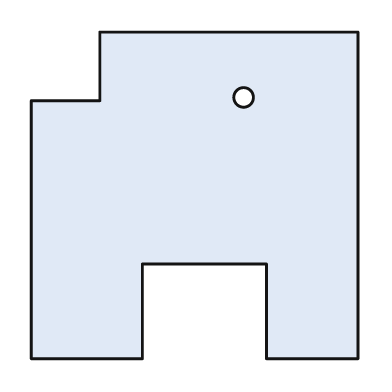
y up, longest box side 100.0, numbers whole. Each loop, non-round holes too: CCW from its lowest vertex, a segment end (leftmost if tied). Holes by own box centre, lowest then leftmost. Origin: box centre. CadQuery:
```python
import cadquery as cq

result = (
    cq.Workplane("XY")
    .moveTo(-50.0, -50.0)
    .lineTo(-16.0, -50.0)
    .lineTo(-16.0, -21.0)
    .lineTo(22.0, -21.0)
    .lineTo(22.0, -50.0)
    .lineTo(50.0, -50.0)
    .lineTo(50.0, 50.0)
    .lineTo(-29.0, 50.0)
    .lineTo(-29.0, 29.0)
    .lineTo(-50.0, 29.0)
    .close()
    .moveTo(15.0, 30.0)
    .circle(3.0)
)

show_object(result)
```